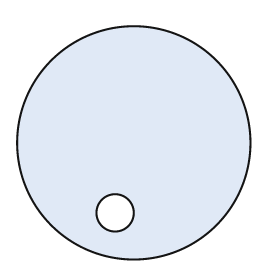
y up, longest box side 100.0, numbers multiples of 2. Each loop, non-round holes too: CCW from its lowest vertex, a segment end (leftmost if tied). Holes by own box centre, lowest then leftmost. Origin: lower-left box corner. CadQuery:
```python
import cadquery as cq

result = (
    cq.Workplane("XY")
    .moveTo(50.0, 50.0)
    .circle(50.0)
    .moveTo(42.0, 20.0)
    .circle(8.0)
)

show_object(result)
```